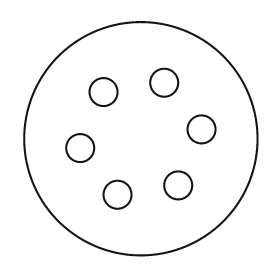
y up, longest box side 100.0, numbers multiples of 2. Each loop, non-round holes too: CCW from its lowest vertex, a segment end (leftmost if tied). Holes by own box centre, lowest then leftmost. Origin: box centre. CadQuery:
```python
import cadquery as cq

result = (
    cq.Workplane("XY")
    .moveTo(0.0, 0.0)
    .circle(50.0)
    .moveTo(-10.0, -24.0)
    .circle(6.0)
    .moveTo(16.0, -20.0)
    .circle(6.0)
    .moveTo(-26.0, -4.0)
    .circle(6.0)
    .moveTo(26.0, 4.0)
    .circle(6.0)
    .moveTo(-16.0, 20.0)
    .circle(6.0)
    .moveTo(10.0, 24.0)
    .circle(6.0)
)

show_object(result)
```